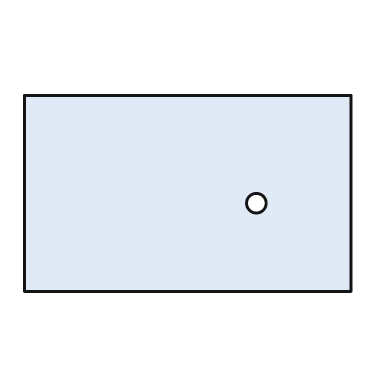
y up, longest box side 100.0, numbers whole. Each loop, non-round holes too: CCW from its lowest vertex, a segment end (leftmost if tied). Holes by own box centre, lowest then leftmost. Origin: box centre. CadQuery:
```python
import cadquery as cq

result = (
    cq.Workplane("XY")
    .moveTo(-50.0, -30.0)
    .lineTo(50.0, -30.0)
    .lineTo(50.0, 30.0)
    .lineTo(-50.0, 30.0)
    .close()
    .moveTo(21.0, -3.0)
    .circle(3.0)
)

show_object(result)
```